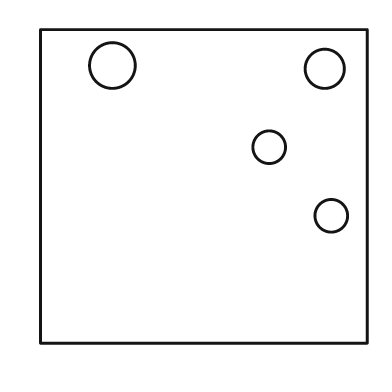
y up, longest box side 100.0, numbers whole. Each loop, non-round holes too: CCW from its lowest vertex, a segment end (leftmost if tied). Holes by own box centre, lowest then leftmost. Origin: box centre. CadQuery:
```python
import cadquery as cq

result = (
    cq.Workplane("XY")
    .moveTo(-50.0, -48.0)
    .lineTo(50.0, -48.0)
    .lineTo(50.0, 48.0)
    .lineTo(-50.0, 48.0)
    .close()
    .moveTo(39.0, -9.0)
    .circle(5.0)
    .moveTo(20.0, 12.0)
    .circle(5.0)
    .moveTo(37.0, 36.0)
    .circle(6.0)
    .moveTo(-28.0, 37.0)
    .circle(7.0)
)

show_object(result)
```